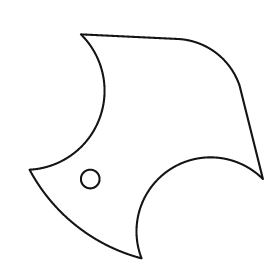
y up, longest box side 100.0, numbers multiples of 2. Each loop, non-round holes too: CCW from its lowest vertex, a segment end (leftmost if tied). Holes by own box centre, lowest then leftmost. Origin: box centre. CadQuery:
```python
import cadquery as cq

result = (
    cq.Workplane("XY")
    .moveTo(-2.0, -48.0)
    .threePointArc((10.0, -10.0), (50.0, -14.0))
    .lineTo(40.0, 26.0)
    .threePointArc((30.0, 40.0), (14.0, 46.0))
    .lineTo(-28.0, 48.0)
    .threePointArc((-20.0, 12.0), (-50.0, -10.0))
    .threePointArc((-30.0, -34.0), (-2.0, -48.0))
    .close()
    .moveTo(-24.0, -14.0)
    .circle(4.0)
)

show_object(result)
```